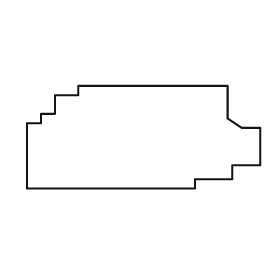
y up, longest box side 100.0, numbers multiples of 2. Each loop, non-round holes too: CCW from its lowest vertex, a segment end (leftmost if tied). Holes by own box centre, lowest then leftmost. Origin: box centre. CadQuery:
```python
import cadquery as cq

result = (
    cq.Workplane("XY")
    .moveTo(-50.0, -22.0)
    .lineTo(22.0, -22.0)
    .lineTo(22.0, -18.0)
    .lineTo(38.0, -18.0)
    .lineTo(38.0, -12.0)
    .lineTo(50.0, -12.0)
    .lineTo(50.0, 4.0)
    .lineTo(42.0, 4.0)
    .lineTo(36.0, 8.0)
    .lineTo(36.0, 22.0)
    .lineTo(-28.0, 22.0)
    .lineTo(-28.0, 18.0)
    .lineTo(-38.0, 18.0)
    .lineTo(-38.0, 10.0)
    .lineTo(-44.0, 10.0)
    .lineTo(-44.0, 6.0)
    .lineTo(-50.0, 6.0)
    .close()
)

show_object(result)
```